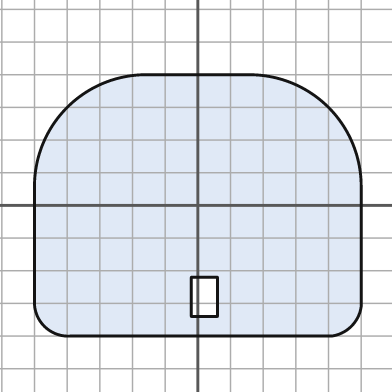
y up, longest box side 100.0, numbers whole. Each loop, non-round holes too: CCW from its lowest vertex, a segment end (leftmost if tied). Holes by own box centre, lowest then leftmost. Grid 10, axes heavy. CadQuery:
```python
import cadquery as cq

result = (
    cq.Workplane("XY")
    .moveTo(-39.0, -40.0)
    .lineTo(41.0, -40.0)
    .threePointArc((47.0, -37.0), (50.0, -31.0))
    .lineTo(50.0, 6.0)
    .threePointArc((40.0, 30.0), (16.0, 40.0))
    .lineTo(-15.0, 40.0)
    .threePointArc((-40.0, 30.0), (-50.0, 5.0))
    .lineTo(-50.0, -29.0)
    .threePointArc((-47.0, -37.0), (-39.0, -40.0))
    .close()
    .moveTo(-2.0, -34.0)
    .lineTo(6.0, -34.0)
    .lineTo(6.0, -22.0)
    .lineTo(-2.0, -22.0)
    .close()
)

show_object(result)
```